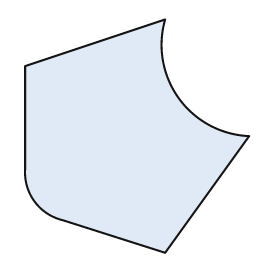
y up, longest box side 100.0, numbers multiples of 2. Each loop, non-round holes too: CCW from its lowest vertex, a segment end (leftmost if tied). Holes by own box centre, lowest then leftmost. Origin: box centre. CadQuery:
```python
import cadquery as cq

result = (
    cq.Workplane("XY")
    .moveTo(12.0, -50.0)
    .lineTo(48.0, 0.0)
    .threePointArc((18.0, 16.0), (12.0, 50.0))
    .lineTo(-48.0, 30.0)
    .lineTo(-48.0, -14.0)
    .threePointArc((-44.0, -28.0), (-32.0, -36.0))
    .close()
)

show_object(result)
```